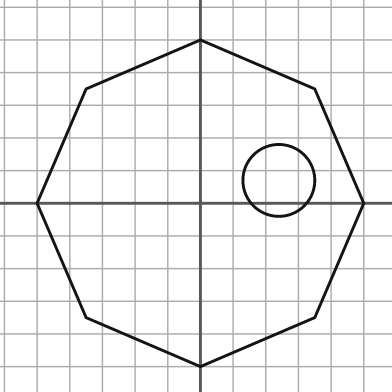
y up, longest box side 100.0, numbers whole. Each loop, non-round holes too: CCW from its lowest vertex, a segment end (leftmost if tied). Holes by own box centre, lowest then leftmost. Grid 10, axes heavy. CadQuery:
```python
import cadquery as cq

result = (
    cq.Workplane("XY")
    .moveTo(0.0, -50.0)
    .lineTo(35.0, -35.0)
    .lineTo(50.0, 0.0)
    .lineTo(35.0, 35.0)
    .lineTo(0.0, 50.0)
    .lineTo(-35.0, 35.0)
    .lineTo(-50.0, 0.0)
    .lineTo(-35.0, -35.0)
    .close()
    .moveTo(24.0, 7.0)
    .circle(11.0)
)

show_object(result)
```